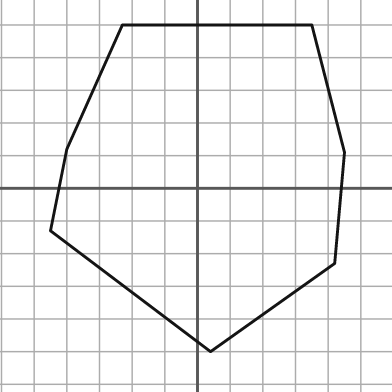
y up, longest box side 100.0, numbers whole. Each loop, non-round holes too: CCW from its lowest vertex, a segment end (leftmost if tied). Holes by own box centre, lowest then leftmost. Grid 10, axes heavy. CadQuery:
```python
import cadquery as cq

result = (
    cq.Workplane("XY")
    .moveTo(4.0, -50.0)
    .lineTo(42.0, -23.0)
    .lineTo(45.0, 11.0)
    .lineTo(35.0, 50.0)
    .lineTo(-23.0, 50.0)
    .lineTo(-40.0, 12.0)
    .lineTo(-45.0, -13.0)
    .close()
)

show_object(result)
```